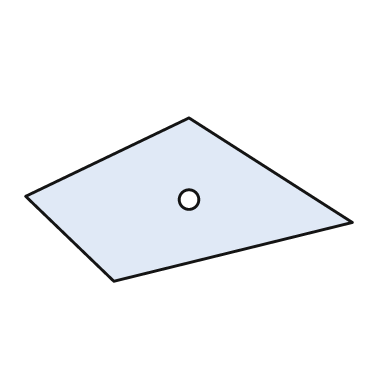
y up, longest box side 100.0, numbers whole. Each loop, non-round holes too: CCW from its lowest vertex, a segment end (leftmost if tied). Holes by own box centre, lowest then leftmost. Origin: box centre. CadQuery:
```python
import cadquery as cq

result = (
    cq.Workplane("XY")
    .moveTo(-23.0, -25.0)
    .lineTo(50.0, -7.0)
    .lineTo(0.0, 25.0)
    .lineTo(-50.0, 1.0)
    .close()
    .moveTo(0.0, 0.0)
    .circle(3.0)
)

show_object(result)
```